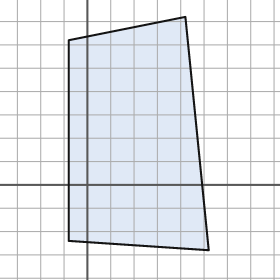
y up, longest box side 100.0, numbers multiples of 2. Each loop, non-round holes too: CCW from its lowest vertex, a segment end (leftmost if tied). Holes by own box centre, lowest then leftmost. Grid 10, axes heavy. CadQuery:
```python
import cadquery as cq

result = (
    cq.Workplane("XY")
    .moveTo(52.0, -28.0)
    .lineTo(42.0, 72.0)
    .lineTo(-8.0, 62.0)
    .lineTo(-8.0, -24.0)
    .close()
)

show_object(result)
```